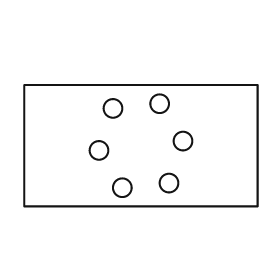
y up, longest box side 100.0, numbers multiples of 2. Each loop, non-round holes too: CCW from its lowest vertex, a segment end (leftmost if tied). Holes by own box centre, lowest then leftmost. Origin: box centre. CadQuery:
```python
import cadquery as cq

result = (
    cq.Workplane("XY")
    .moveTo(-50.0, -26.0)
    .lineTo(50.0, -26.0)
    .lineTo(50.0, 26.0)
    .lineTo(-50.0, 26.0)
    .close()
    .moveTo(-8.0, -18.0)
    .circle(4.0)
    .moveTo(12.0, -16.0)
    .circle(4.0)
    .moveTo(-18.0, -2.0)
    .circle(4.0)
    .moveTo(18.0, 2.0)
    .circle(4.0)
    .moveTo(-12.0, 16.0)
    .circle(4.0)
    .moveTo(8.0, 18.0)
    .circle(4.0)
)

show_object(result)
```